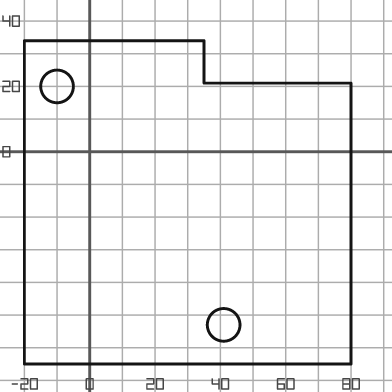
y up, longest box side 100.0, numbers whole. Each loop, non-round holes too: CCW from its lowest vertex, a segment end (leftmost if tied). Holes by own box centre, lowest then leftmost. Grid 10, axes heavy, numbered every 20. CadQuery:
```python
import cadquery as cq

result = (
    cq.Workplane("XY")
    .moveTo(-20.0, -65.0)
    .lineTo(80.0, -65.0)
    .lineTo(80.0, 21.0)
    .lineTo(35.0, 21.0)
    .lineTo(35.0, 34.0)
    .lineTo(-20.0, 34.0)
    .close()
    .moveTo(41.0, -53.0)
    .circle(5.0)
    .moveTo(-10.0, 20.0)
    .circle(5.0)
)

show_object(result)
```